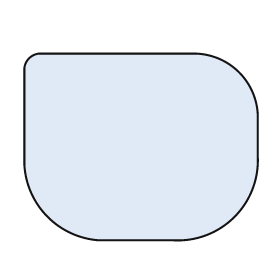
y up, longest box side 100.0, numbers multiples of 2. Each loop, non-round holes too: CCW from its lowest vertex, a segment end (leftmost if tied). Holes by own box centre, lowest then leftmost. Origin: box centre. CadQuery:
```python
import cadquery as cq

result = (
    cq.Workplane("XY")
    .moveTo(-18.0, -40.0)
    .lineTo(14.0, -40.0)
    .threePointArc((40.0, -30.0), (50.0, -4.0))
    .lineTo(50.0, 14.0)
    .threePointArc((42.0, 32.0), (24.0, 40.0))
    .lineTo(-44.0, 40.0)
    .threePointArc((-48.0, 38.0), (-50.0, 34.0))
    .lineTo(-50.0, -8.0)
    .threePointArc((-40.0, -30.0), (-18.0, -40.0))
    .close()
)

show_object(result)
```